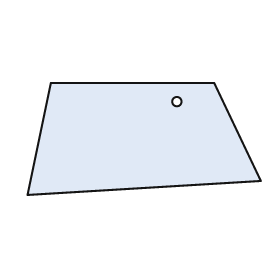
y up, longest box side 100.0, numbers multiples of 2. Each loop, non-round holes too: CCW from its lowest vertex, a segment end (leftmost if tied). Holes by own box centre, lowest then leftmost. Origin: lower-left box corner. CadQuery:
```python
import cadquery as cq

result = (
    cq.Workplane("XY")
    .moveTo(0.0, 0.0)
    .lineTo(100.0, 6.0)
    .lineTo(80.0, 48.0)
    .lineTo(10.0, 48.0)
    .close()
    .moveTo(64.0, 40.0)
    .circle(2.0)
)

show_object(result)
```